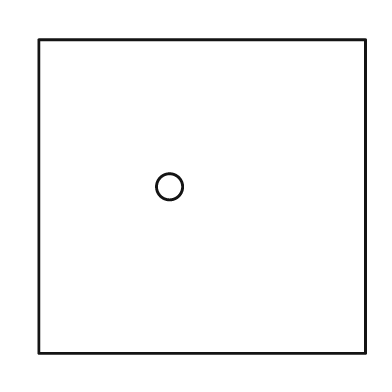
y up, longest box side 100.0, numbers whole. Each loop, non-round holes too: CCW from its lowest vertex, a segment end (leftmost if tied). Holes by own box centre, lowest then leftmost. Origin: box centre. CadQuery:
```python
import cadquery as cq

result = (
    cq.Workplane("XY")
    .moveTo(-50.0, -48.0)
    .lineTo(50.0, -48.0)
    .lineTo(50.0, 48.0)
    .lineTo(-50.0, 48.0)
    .close()
    .moveTo(-10.0, 3.0)
    .circle(4.0)
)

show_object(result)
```